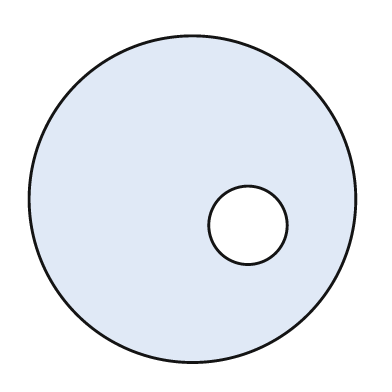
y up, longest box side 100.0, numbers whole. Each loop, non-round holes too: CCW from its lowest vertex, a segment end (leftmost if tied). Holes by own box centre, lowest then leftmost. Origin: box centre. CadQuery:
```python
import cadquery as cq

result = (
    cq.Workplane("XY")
    .moveTo(0.0, 0.0)
    .circle(50.0)
    .moveTo(17.0, -8.0)
    .circle(12.0)
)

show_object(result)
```